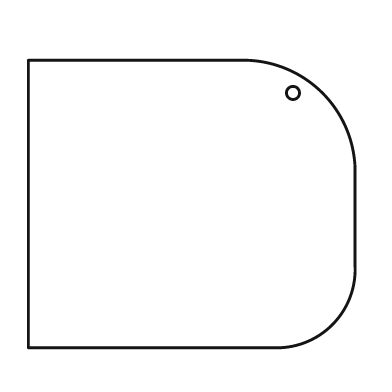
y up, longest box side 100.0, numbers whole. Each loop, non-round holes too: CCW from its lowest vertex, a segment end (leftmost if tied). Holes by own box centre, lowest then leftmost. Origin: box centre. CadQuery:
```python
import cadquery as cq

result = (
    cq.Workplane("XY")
    .moveTo(-50.0, -44.0)
    .lineTo(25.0, -44.0)
    .threePointArc((43.0, -37.0), (50.0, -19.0))
    .lineTo(50.0, 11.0)
    .threePointArc((40.0, 34.0), (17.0, 44.0))
    .lineTo(-50.0, 44.0)
    .close()
    .moveTo(31.0, 34.0)
    .circle(2.0)
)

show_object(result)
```